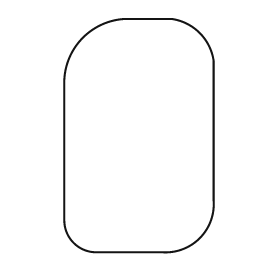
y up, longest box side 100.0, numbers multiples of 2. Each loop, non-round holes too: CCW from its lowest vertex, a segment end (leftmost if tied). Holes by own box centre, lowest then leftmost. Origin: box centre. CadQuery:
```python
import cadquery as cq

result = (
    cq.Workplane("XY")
    .moveTo(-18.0, -50.0)
    .lineTo(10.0, -50.0)
    .threePointArc((26.0, -44.0), (32.0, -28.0))
    .lineTo(32.0, 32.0)
    .threePointArc((26.0, 44.0), (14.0, 50.0))
    .lineTo(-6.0, 50.0)
    .threePointArc((-24.0, 42.0), (-32.0, 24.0))
    .lineTo(-32.0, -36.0)
    .threePointArc((-28.0, -46.0), (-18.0, -50.0))
    .close()
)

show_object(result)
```